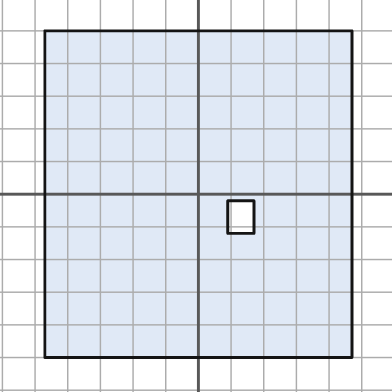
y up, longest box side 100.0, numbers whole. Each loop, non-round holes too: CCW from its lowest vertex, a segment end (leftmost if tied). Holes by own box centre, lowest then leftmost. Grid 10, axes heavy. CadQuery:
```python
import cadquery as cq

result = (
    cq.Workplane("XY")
    .moveTo(-47.0, -50.0)
    .lineTo(47.0, -50.0)
    .lineTo(47.0, 50.0)
    .lineTo(-47.0, 50.0)
    .close()
    .moveTo(9.0, -12.0)
    .lineTo(17.0, -12.0)
    .lineTo(17.0, -2.0)
    .lineTo(9.0, -2.0)
    .close()
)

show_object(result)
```